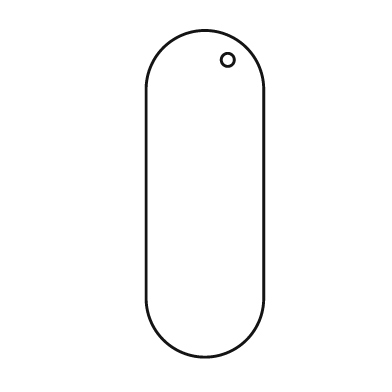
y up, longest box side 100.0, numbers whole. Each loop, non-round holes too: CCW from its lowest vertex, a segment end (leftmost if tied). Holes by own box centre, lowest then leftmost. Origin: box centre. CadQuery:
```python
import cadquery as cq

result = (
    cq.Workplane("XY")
    .moveTo(-18.0, -32.0)
    .threePointArc((0.0, -50.0), (18.0, -32.0))
    .lineTo(18.0, 32.0)
    .threePointArc((0.0, 50.0), (-18.0, 32.0))
    .close()
    .moveTo(7.0, 41.0)
    .circle(2.0)
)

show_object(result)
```